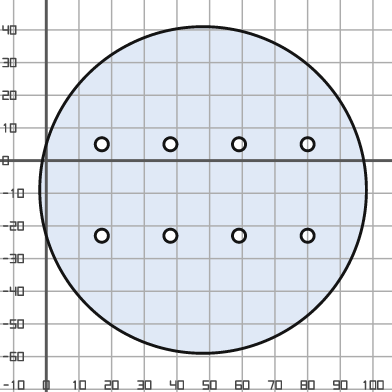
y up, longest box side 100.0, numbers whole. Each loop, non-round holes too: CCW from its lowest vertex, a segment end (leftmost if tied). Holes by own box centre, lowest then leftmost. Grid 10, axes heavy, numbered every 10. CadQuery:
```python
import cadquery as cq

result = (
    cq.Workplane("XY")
    .moveTo(48.0, -9.0)
    .circle(50.0)
    .moveTo(17.0, -23.0)
    .circle(2.0)
    .moveTo(38.0, -23.0)
    .circle(2.0)
    .moveTo(59.0, -23.0)
    .circle(2.0)
    .moveTo(80.0, -23.0)
    .circle(2.0)
    .moveTo(17.0, 5.0)
    .circle(2.0)
    .moveTo(38.0, 5.0)
    .circle(2.0)
    .moveTo(59.0, 5.0)
    .circle(2.0)
    .moveTo(80.0, 5.0)
    .circle(2.0)
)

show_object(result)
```